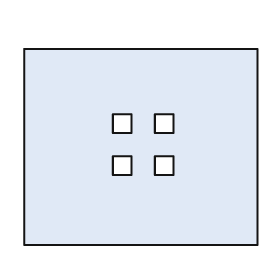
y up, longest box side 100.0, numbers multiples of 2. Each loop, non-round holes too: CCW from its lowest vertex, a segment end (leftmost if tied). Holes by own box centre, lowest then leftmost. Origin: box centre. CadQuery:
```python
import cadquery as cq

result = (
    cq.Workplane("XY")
    .moveTo(-50.0, -42.0)
    .lineTo(50.0, -42.0)
    .lineTo(50.0, 42.0)
    .lineTo(-50.0, 42.0)
    .close()
    .moveTo(-12.0, -12.0)
    .lineTo(-4.0, -12.0)
    .lineTo(-4.0, -4.0)
    .lineTo(-12.0, -4.0)
    .close()
    .moveTo(6.0, -12.0)
    .lineTo(14.0, -12.0)
    .lineTo(14.0, -4.0)
    .lineTo(6.0, -4.0)
    .close()
    .moveTo(-12.0, 6.0)
    .lineTo(-4.0, 6.0)
    .lineTo(-4.0, 14.0)
    .lineTo(-12.0, 14.0)
    .close()
    .moveTo(6.0, 6.0)
    .lineTo(14.0, 6.0)
    .lineTo(14.0, 14.0)
    .lineTo(6.0, 14.0)
    .close()
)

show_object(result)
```